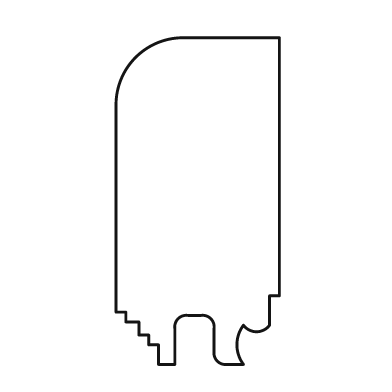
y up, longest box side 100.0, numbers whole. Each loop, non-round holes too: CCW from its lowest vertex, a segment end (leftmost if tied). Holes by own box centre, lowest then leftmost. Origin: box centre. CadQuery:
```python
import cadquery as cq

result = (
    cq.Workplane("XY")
    .moveTo(-12.0, -50.0)
    .lineTo(-7.0, -50.0)
    .lineTo(-7.0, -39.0)
    .threePointArc((-6.0, -36.0), (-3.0, -35.0))
    .lineTo(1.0, -35.0)
    .threePointArc((4.0, -36.0), (5.0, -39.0))
    .lineTo(5.0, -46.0)
    .threePointArc((6.0, -49.0), (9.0, -50.0))
    .lineTo(14.0, -50.0)
    .threePointArc((12.0, -44.0), (14.0, -38.0))
    .threePointArc((18.0, -40.0), (22.0, -38.0))
    .lineTo(22.0, -29.0)
    .lineTo(25.0, -29.0)
    .lineTo(25.0, 50.0)
    .lineTo(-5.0, 50.0)
    .threePointArc((-19.0, 44.0), (-25.0, 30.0))
    .lineTo(-25.0, -34.0)
    .lineTo(-22.0, -34.0)
    .lineTo(-22.0, -37.0)
    .lineTo(-18.0, -37.0)
    .lineTo(-18.0, -41.0)
    .lineTo(-15.0, -41.0)
    .lineTo(-15.0, -44.0)
    .lineTo(-12.0, -44.0)
    .close()
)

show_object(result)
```